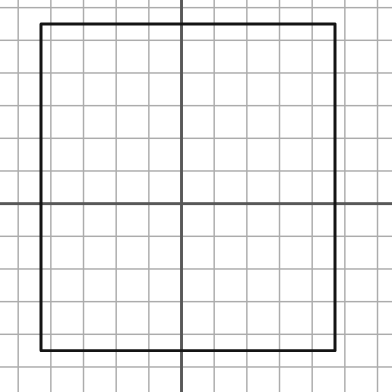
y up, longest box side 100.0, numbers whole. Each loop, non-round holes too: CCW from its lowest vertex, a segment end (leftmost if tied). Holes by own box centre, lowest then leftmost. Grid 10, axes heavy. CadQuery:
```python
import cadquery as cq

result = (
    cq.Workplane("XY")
    .moveTo(-43.0, -45.0)
    .lineTo(47.0, -45.0)
    .lineTo(47.0, 55.0)
    .lineTo(-43.0, 55.0)
    .close()
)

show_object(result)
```